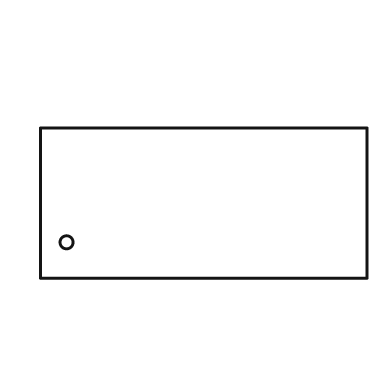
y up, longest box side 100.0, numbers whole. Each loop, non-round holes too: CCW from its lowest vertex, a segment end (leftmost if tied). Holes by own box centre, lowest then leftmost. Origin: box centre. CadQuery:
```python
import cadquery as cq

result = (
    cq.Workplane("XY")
    .moveTo(-50.0, -23.0)
    .lineTo(50.0, -23.0)
    .lineTo(50.0, 23.0)
    .lineTo(-50.0, 23.0)
    .close()
    .moveTo(-42.0, -12.0)
    .circle(2.0)
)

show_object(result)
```